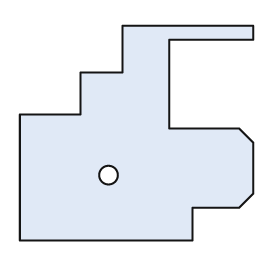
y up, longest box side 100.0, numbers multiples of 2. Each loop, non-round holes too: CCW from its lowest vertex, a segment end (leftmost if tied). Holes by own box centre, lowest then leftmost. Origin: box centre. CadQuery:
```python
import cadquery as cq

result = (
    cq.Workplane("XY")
    .moveTo(-50.0, -46.0)
    .lineTo(24.0, -46.0)
    .lineTo(24.0, -32.0)
    .lineTo(44.0, -32.0)
    .lineTo(50.0, -26.0)
    .lineTo(50.0, -4.0)
    .lineTo(44.0, 2.0)
    .lineTo(14.0, 2.0)
    .lineTo(14.0, 40.0)
    .lineTo(50.0, 40.0)
    .lineTo(50.0, 46.0)
    .lineTo(-6.0, 46.0)
    .lineTo(-6.0, 26.0)
    .lineTo(-24.0, 26.0)
    .lineTo(-24.0, 8.0)
    .lineTo(-50.0, 8.0)
    .close()
    .moveTo(-12.0, -18.0)
    .circle(4.0)
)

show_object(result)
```